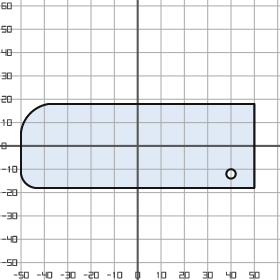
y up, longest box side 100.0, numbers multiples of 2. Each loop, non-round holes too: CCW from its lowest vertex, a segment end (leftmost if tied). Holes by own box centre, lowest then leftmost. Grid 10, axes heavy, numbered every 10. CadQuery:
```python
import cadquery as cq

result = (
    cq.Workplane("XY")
    .moveTo(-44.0, -18.0)
    .lineTo(50.0, -18.0)
    .lineTo(50.0, 18.0)
    .lineTo(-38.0, 18.0)
    .threePointArc((-46.0, 14.0), (-50.0, 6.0))
    .lineTo(-50.0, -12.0)
    .threePointArc((-48.0, -16.0), (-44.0, -18.0))
    .close()
    .moveTo(40.0, -12.0)
    .circle(2.0)
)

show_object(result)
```